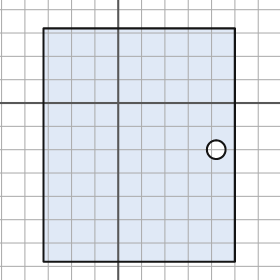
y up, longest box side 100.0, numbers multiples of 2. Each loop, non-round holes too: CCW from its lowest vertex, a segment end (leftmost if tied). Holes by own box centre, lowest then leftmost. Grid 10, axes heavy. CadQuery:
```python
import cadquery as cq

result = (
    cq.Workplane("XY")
    .moveTo(-32.0, -68.0)
    .lineTo(50.0, -68.0)
    .lineTo(50.0, 32.0)
    .lineTo(-32.0, 32.0)
    .close()
    .moveTo(42.0, -20.0)
    .circle(4.0)
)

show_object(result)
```